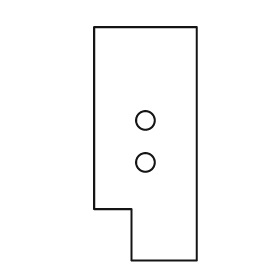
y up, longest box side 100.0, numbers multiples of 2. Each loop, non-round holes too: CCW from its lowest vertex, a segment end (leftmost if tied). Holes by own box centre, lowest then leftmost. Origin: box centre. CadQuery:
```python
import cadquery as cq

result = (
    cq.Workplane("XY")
    .moveTo(-6.0, -50.0)
    .lineTo(22.0, -50.0)
    .lineTo(22.0, 50.0)
    .lineTo(-22.0, 50.0)
    .lineTo(-22.0, -28.0)
    .lineTo(-6.0, -28.0)
    .close()
    .moveTo(0.0, -8.0)
    .circle(4.0)
    .moveTo(0.0, 10.0)
    .circle(4.0)
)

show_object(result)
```